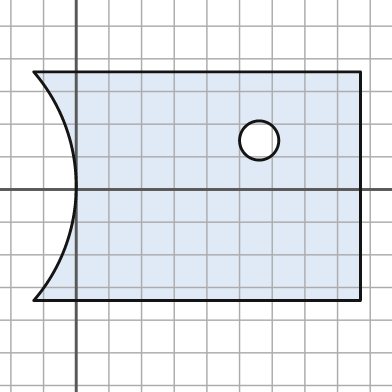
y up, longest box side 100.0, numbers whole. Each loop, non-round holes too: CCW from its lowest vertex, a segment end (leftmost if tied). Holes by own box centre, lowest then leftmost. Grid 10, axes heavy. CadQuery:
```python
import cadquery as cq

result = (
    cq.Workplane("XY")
    .moveTo(-13.0, -34.0)
    .lineTo(87.0, -34.0)
    .lineTo(87.0, 36.0)
    .lineTo(-13.0, 36.0)
    .threePointArc((0.0, 1.0), (-13.0, -34.0))
    .close()
    .moveTo(56.0, 15.0)
    .circle(6.0)
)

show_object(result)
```